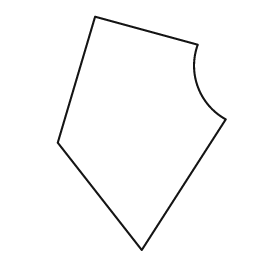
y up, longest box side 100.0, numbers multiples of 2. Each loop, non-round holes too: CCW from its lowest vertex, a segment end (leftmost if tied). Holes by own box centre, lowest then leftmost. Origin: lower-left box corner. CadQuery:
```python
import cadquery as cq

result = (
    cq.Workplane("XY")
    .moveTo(36.0, 0.0)
    .lineTo(72.0, 56.0)
    .threePointArc((60.0, 70.0), (60.0, 88.0))
    .lineTo(16.0, 100.0)
    .lineTo(0.0, 46.0)
    .close()
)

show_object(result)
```